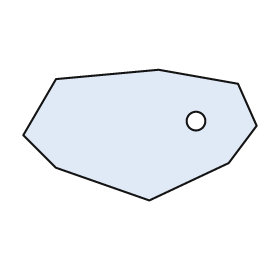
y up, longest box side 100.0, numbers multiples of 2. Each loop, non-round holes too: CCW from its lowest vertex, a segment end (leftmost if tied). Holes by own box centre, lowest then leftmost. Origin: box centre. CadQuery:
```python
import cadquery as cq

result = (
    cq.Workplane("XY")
    .moveTo(4.0, -28.0)
    .lineTo(38.0, -12.0)
    .lineTo(50.0, 4.0)
    .lineTo(42.0, 22.0)
    .lineTo(8.0, 28.0)
    .lineTo(-36.0, 24.0)
    .lineTo(-50.0, 0.0)
    .lineTo(-36.0, -14.0)
    .close()
    .moveTo(24.0, 6.0)
    .circle(4.0)
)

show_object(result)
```